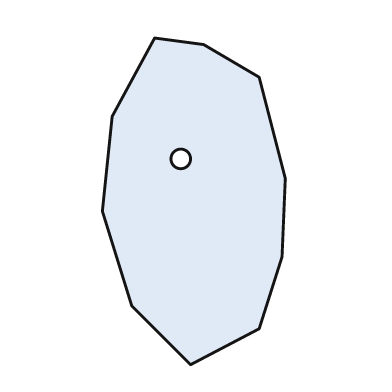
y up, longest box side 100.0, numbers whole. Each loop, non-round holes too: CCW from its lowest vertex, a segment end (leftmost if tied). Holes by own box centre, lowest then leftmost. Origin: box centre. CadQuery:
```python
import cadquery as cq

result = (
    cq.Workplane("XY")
    .moveTo(-1.0, -50.0)
    .lineTo(20.0, -39.0)
    .lineTo(27.0, -17.0)
    .lineTo(28.0, 7.0)
    .lineTo(20.0, 38.0)
    .lineTo(3.0, 48.0)
    .lineTo(-12.0, 50.0)
    .lineTo(-25.0, 26.0)
    .lineTo(-28.0, -3.0)
    .lineTo(-19.0, -32.0)
    .close()
    .moveTo(-4.0, 13.0)
    .circle(3.0)
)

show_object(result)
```